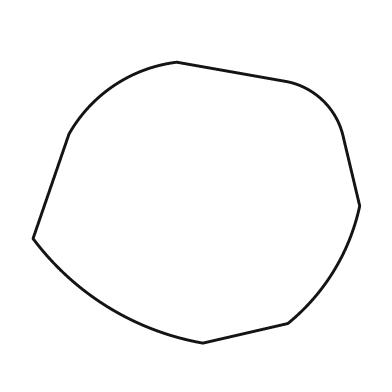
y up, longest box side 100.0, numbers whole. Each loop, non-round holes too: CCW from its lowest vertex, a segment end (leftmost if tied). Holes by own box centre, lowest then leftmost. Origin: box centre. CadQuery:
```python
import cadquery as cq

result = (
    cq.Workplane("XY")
    .moveTo(2.0, -43.0)
    .lineTo(28.0, -37.0)
    .threePointArc((42.0, -21.0), (50.0, -1.0))
    .lineTo(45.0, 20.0)
    .threePointArc((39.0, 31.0), (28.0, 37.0))
    .lineTo(-6.0, 43.0)
    .threePointArc((-25.0, 36.0), (-39.0, 21.0))
    .lineTo(-50.0, -11.0)
    .threePointArc((-27.0, -32.0), (2.0, -43.0))
    .close()
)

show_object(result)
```